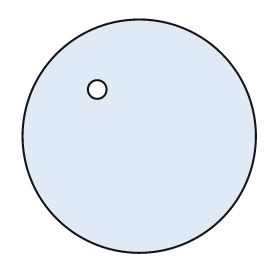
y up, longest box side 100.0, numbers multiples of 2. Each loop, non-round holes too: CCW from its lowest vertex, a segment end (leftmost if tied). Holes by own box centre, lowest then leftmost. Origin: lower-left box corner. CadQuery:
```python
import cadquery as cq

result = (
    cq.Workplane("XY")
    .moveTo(50.0, 50.0)
    .circle(50.0)
    .moveTo(32.0, 70.0)
    .circle(4.0)
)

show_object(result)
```